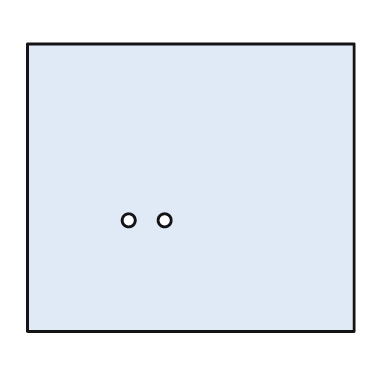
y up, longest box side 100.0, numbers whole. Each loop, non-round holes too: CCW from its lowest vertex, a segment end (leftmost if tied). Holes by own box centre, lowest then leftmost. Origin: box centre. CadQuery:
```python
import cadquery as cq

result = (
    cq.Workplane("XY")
    .moveTo(-50.0, -44.0)
    .lineTo(50.0, -44.0)
    .lineTo(50.0, 44.0)
    .lineTo(-50.0, 44.0)
    .close()
    .moveTo(-19.0, -10.0)
    .circle(2.0)
    .moveTo(-8.0, -10.0)
    .circle(2.0)
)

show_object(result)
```